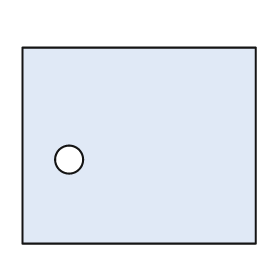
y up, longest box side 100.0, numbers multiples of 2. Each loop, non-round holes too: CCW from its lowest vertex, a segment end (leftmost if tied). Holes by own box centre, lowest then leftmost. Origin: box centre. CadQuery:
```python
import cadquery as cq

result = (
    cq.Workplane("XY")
    .moveTo(-50.0, -42.0)
    .lineTo(50.0, -42.0)
    .lineTo(50.0, 42.0)
    .lineTo(-50.0, 42.0)
    .close()
    .moveTo(-30.0, -6.0)
    .circle(6.0)
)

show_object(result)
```